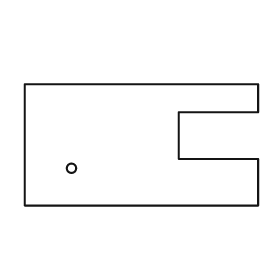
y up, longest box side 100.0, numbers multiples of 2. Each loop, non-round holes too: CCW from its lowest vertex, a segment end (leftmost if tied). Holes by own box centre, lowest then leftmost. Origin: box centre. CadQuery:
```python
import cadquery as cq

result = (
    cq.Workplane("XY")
    .moveTo(-50.0, -26.0)
    .lineTo(50.0, -26.0)
    .lineTo(50.0, -6.0)
    .lineTo(16.0, -6.0)
    .lineTo(16.0, 14.0)
    .lineTo(50.0, 14.0)
    .lineTo(50.0, 26.0)
    .lineTo(-50.0, 26.0)
    .close()
    .moveTo(-30.0, -10.0)
    .circle(2.0)
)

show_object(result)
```